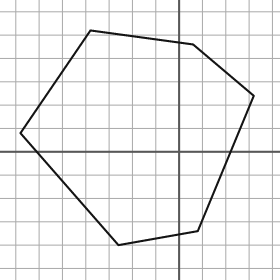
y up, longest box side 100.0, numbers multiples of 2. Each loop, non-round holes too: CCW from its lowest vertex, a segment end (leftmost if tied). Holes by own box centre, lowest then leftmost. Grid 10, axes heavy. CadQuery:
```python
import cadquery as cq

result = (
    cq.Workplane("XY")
    .moveTo(-26.0, -40.0)
    .lineTo(8.0, -34.0)
    .lineTo(32.0, 24.0)
    .lineTo(6.0, 46.0)
    .lineTo(-38.0, 52.0)
    .lineTo(-68.0, 8.0)
    .close()
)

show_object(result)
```